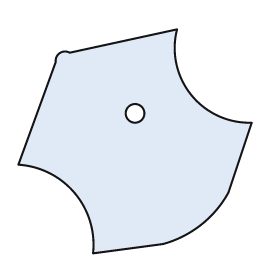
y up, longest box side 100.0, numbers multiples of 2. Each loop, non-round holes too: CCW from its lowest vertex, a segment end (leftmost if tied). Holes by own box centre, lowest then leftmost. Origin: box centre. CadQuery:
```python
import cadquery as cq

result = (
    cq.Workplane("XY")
    .moveTo(-18.0, -48.0)
    .lineTo(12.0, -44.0)
    .threePointArc((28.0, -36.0), (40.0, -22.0))
    .lineTo(50.0, 8.0)
    .threePointArc((24.0, 20.0), (18.0, 48.0))
    .lineTo(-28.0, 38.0)
    .threePointArc((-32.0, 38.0), (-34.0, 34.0))
    .lineTo(-50.0, -10.0)
    .threePointArc((-26.0, -22.0), (-18.0, -48.0))
    .close()
    .moveTo(0.0, 12.0)
    .circle(4.0)
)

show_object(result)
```